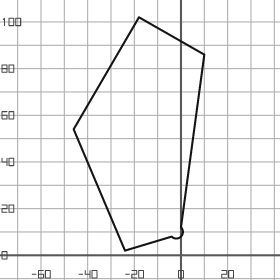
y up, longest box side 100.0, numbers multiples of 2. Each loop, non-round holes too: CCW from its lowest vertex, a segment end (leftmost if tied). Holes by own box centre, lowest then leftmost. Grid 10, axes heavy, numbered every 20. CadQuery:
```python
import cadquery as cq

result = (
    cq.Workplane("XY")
    .moveTo(-24.0, 2.0)
    .lineTo(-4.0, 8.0)
    .threePointArc((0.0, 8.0), (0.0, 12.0))
    .lineTo(10.0, 86.0)
    .lineTo(-18.0, 102.0)
    .lineTo(-46.0, 54.0)
    .close()
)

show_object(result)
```